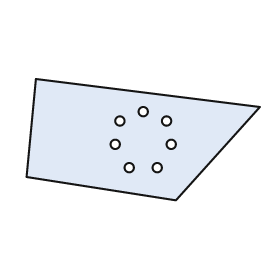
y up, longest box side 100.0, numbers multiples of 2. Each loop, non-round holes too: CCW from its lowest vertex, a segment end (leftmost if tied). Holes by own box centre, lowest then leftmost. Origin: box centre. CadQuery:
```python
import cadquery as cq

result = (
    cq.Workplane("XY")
    .moveTo(14.0, -26.0)
    .lineTo(50.0, 14.0)
    .lineTo(-46.0, 26.0)
    .lineTo(-50.0, -16.0)
    .close()
    .moveTo(-6.0, -12.0)
    .circle(2.0)
    .moveTo(6.0, -12.0)
    .circle(2.0)
    .moveTo(-12.0, -2.0)
    .circle(2.0)
    .moveTo(12.0, -2.0)
    .circle(2.0)
    .moveTo(-10.0, 8.0)
    .circle(2.0)
    .moveTo(10.0, 8.0)
    .circle(2.0)
    .moveTo(0.0, 12.0)
    .circle(2.0)
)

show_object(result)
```